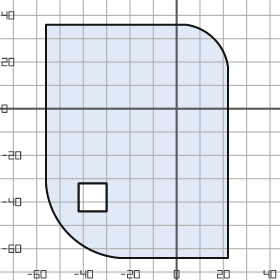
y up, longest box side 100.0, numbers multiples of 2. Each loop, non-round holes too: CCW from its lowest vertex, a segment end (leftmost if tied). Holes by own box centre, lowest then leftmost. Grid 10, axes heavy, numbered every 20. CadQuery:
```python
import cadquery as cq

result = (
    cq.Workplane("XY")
    .moveTo(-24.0, -64.0)
    .lineTo(22.0, -64.0)
    .lineTo(22.0, 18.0)
    .threePointArc((16.0, 30.0), (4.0, 36.0))
    .lineTo(-56.0, 36.0)
    .lineTo(-56.0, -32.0)
    .threePointArc((-46.0, -54.0), (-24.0, -64.0))
    .close()
    .moveTo(-42.0, -44.0)
    .lineTo(-30.0, -44.0)
    .lineTo(-30.0, -32.0)
    .lineTo(-42.0, -32.0)
    .close()
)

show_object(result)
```